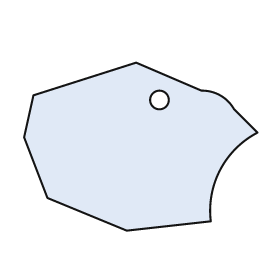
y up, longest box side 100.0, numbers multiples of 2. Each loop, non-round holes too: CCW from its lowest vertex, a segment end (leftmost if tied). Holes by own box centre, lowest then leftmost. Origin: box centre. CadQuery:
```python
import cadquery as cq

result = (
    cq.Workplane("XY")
    .moveTo(-6.0, -36.0)
    .lineTo(30.0, -32.0)
    .threePointArc((34.0, -10.0), (50.0, 6.0))
    .lineTo(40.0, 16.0)
    .threePointArc((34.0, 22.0), (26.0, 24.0))
    .lineTo(-2.0, 36.0)
    .lineTo(-46.0, 22.0)
    .lineTo(-50.0, 4.0)
    .lineTo(-40.0, -22.0)
    .close()
    .moveTo(8.0, 20.0)
    .circle(4.0)
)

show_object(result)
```